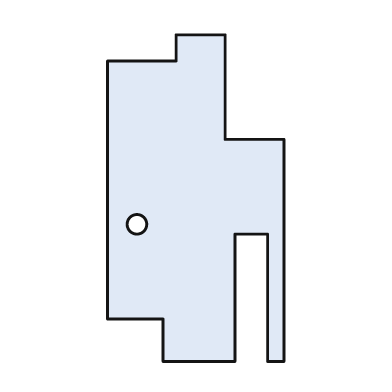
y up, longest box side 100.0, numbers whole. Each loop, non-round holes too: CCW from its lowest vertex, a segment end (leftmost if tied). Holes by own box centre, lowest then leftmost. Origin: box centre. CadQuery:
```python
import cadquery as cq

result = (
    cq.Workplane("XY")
    .moveTo(-10.0, -50.0)
    .lineTo(12.0, -50.0)
    .lineTo(12.0, -11.0)
    .lineTo(22.0, -11.0)
    .lineTo(22.0, -50.0)
    .lineTo(27.0, -50.0)
    .lineTo(27.0, 18.0)
    .lineTo(9.0, 18.0)
    .lineTo(9.0, 50.0)
    .lineTo(-6.0, 50.0)
    .lineTo(-6.0, 42.0)
    .lineTo(-27.0, 42.0)
    .lineTo(-27.0, -37.0)
    .lineTo(-10.0, -37.0)
    .close()
    .moveTo(-18.0, -8.0)
    .circle(3.0)
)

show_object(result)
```